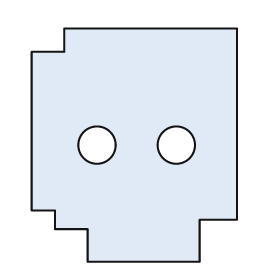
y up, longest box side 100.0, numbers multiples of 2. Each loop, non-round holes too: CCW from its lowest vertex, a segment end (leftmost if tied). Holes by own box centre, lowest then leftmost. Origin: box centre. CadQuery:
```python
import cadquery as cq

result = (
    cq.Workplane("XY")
    .moveTo(-20.0, -50.0)
    .lineTo(28.0, -50.0)
    .lineTo(28.0, -32.0)
    .lineTo(44.0, -32.0)
    .lineTo(44.0, 50.0)
    .lineTo(-30.0, 50.0)
    .lineTo(-30.0, 40.0)
    .lineTo(-44.0, 40.0)
    .lineTo(-44.0, -28.0)
    .lineTo(-34.0, -28.0)
    .lineTo(-34.0, -36.0)
    .lineTo(-20.0, -36.0)
    .close()
    .moveTo(-16.0, 0.0)
    .circle(8.0)
    .moveTo(18.0, 0.0)
    .circle(8.0)
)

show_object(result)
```